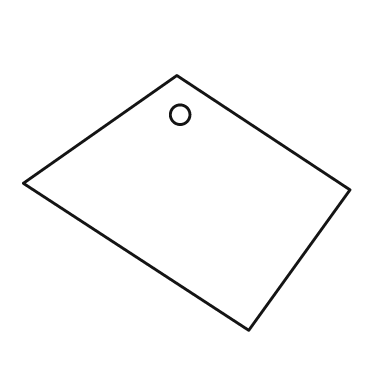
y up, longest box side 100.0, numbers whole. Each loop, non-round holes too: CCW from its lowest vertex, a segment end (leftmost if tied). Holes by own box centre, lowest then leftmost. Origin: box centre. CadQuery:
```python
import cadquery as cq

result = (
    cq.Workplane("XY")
    .moveTo(19.0, -39.0)
    .lineTo(50.0, 4.0)
    .lineTo(-3.0, 39.0)
    .lineTo(-50.0, 6.0)
    .close()
    .moveTo(-2.0, 27.0)
    .circle(3.0)
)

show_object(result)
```